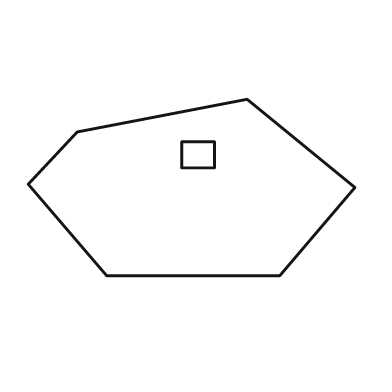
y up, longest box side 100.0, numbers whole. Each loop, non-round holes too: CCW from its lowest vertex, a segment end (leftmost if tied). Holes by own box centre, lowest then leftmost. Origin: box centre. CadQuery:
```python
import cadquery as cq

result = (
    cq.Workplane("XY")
    .moveTo(-26.0, -27.0)
    .lineTo(27.0, -27.0)
    .lineTo(50.0, 0.0)
    .lineTo(17.0, 27.0)
    .lineTo(-35.0, 17.0)
    .lineTo(-50.0, 1.0)
    .close()
    .moveTo(-3.0, 6.0)
    .lineTo(7.0, 6.0)
    .lineTo(7.0, 14.0)
    .lineTo(-3.0, 14.0)
    .close()
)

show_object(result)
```